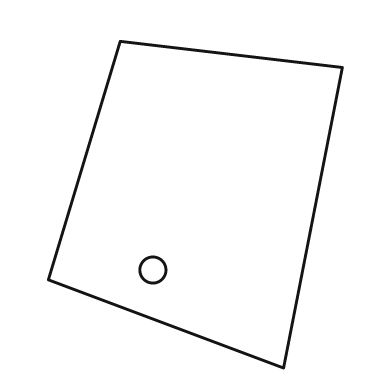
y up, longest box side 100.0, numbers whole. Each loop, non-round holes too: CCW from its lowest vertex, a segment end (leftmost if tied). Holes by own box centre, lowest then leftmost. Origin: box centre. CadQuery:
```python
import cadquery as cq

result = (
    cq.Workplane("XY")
    .moveTo(27.0, -50.0)
    .lineTo(45.0, 42.0)
    .lineTo(-23.0, 50.0)
    .lineTo(-45.0, -23.0)
    .close()
    .moveTo(-13.0, -20.0)
    .circle(4.0)
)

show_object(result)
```